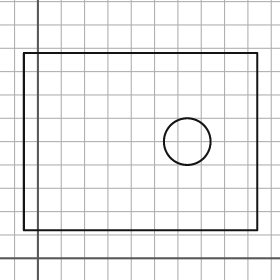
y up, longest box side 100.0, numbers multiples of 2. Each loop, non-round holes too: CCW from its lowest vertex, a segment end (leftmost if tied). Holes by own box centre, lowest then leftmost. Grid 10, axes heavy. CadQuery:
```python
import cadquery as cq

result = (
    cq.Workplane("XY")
    .moveTo(-6.0, 12.0)
    .lineTo(94.0, 12.0)
    .lineTo(94.0, 88.0)
    .lineTo(-6.0, 88.0)
    .close()
    .moveTo(64.0, 50.0)
    .circle(10.0)
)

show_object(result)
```